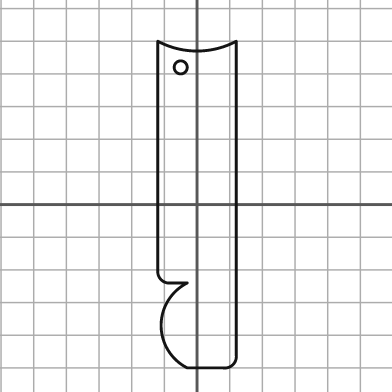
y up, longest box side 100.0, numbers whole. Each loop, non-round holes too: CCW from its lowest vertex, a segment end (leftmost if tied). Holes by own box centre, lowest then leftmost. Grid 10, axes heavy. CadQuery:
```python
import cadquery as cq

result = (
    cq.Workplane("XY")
    .moveTo(-3.0, -50.0)
    .lineTo(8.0, -50.0)
    .threePointArc((11.0, -49.0), (12.0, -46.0))
    .lineTo(12.0, 50.0)
    .threePointArc((0.0, 47.0), (-12.0, 50.0))
    .lineTo(-12.0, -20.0)
    .threePointArc((-11.0, -23.0), (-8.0, -24.0))
    .lineTo(-3.0, -24.0)
    .threePointArc((-11.0, -37.0), (-3.0, -50.0))
    .close()
    .moveTo(-5.0, 42.0)
    .circle(2.0)
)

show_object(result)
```